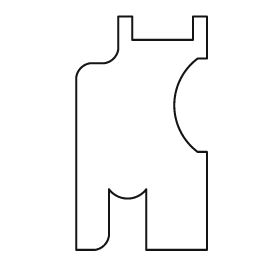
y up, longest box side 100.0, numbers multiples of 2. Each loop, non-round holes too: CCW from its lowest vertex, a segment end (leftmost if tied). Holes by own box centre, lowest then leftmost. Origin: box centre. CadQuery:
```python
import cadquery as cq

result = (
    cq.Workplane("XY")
    .moveTo(-28.0, -50.0)
    .lineTo(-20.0, -50.0)
    .threePointArc((-16.0, -48.0), (-14.0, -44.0))
    .lineTo(-14.0, -24.0)
    .threePointArc((-6.0, -28.0), (2.0, -24.0))
    .lineTo(2.0, -50.0)
    .lineTo(28.0, -50.0)
    .lineTo(28.0, -8.0)
    .lineTo(24.0, -8.0)
    .threePointArc((14.0, 12.0), (24.0, 32.0))
    .lineTo(28.0, 32.0)
    .lineTo(28.0, 50.0)
    .lineTo(22.0, 50.0)
    .lineTo(22.0, 40.0)
    .lineTo(-4.0, 40.0)
    .lineTo(-4.0, 50.0)
    .lineTo(-10.0, 50.0)
    .lineTo(-10.0, 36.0)
    .threePointArc((-12.0, 32.0), (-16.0, 30.0))
    .lineTo(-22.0, 30.0)
    .threePointArc((-26.0, 28.0), (-28.0, 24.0))
    .close()
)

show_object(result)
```